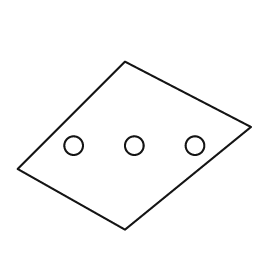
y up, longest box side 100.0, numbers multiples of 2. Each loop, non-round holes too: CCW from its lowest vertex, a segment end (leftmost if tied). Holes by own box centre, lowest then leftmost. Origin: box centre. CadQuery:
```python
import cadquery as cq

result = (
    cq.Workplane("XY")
    .moveTo(-4.0, -36.0)
    .lineTo(50.0, 8.0)
    .lineTo(-4.0, 36.0)
    .lineTo(-50.0, -10.0)
    .close()
    .moveTo(-26.0, 0.0)
    .circle(4.0)
    .moveTo(0.0, 0.0)
    .circle(4.0)
    .moveTo(26.0, 0.0)
    .circle(4.0)
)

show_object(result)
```